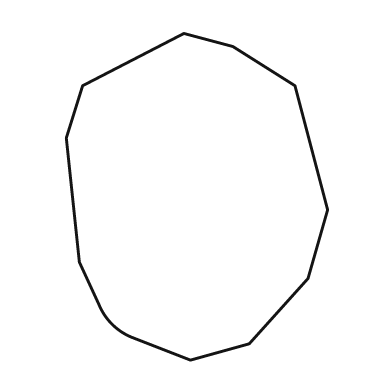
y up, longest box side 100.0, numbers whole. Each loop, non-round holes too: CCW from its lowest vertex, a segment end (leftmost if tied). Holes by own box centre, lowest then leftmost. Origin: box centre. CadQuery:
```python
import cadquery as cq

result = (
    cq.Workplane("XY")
    .moveTo(-2.0, -50.0)
    .lineTo(16.0, -45.0)
    .lineTo(34.0, -25.0)
    .lineTo(40.0, -4.0)
    .lineTo(30.0, 34.0)
    .lineTo(11.0, 46.0)
    .lineTo(-4.0, 50.0)
    .lineTo(-35.0, 34.0)
    .lineTo(-40.0, 18.0)
    .lineTo(-36.0, -20.0)
    .lineTo(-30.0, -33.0)
    .threePointArc((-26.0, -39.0), (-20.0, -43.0))
    .close()
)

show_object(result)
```